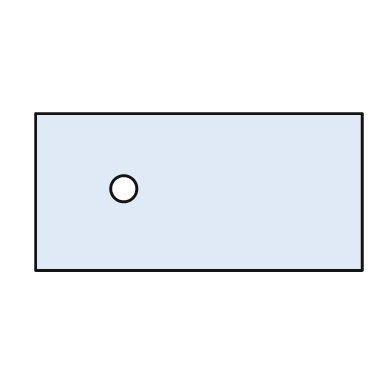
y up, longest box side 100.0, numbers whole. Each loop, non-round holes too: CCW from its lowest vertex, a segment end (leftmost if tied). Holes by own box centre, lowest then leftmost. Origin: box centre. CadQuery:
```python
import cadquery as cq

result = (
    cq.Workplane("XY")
    .moveTo(-50.0, -24.0)
    .lineTo(50.0, -24.0)
    .lineTo(50.0, 24.0)
    .lineTo(-50.0, 24.0)
    .close()
    .moveTo(-23.0, 1.0)
    .circle(4.0)
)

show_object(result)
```